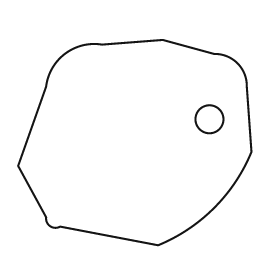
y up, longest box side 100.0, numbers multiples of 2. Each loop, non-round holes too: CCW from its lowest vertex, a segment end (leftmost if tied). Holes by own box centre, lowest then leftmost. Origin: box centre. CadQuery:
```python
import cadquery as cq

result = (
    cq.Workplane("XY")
    .moveTo(10.0, -44.0)
    .threePointArc((34.0, -28.0), (50.0, -4.0))
    .lineTo(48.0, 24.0)
    .threePointArc((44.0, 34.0), (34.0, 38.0))
    .lineTo(12.0, 44.0)
    .lineTo(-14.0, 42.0)
    .threePointArc((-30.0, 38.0), (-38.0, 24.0))
    .lineTo(-50.0, -10.0)
    .lineTo(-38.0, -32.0)
    .threePointArc((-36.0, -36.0), (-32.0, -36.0))
    .close()
    .moveTo(32.0, 10.0)
    .circle(6.0)
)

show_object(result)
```